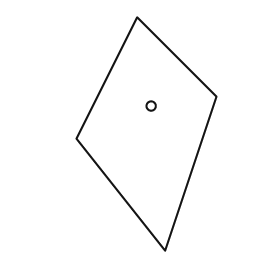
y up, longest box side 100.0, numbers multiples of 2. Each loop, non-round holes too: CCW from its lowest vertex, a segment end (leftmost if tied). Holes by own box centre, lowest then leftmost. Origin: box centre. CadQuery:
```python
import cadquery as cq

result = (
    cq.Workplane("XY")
    .moveTo(8.0, -50.0)
    .lineTo(30.0, 16.0)
    .lineTo(-4.0, 50.0)
    .lineTo(-30.0, -2.0)
    .close()
    .moveTo(2.0, 12.0)
    .circle(2.0)
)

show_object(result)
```